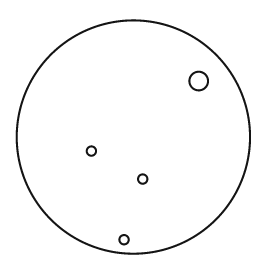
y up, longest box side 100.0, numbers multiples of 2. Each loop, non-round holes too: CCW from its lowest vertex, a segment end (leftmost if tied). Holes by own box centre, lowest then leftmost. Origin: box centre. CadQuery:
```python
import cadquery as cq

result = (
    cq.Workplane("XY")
    .moveTo(0.0, 0.0)
    .circle(50.0)
    .moveTo(-4.0, -44.0)
    .circle(2.0)
    .moveTo(4.0, -18.0)
    .circle(2.0)
    .moveTo(-18.0, -6.0)
    .circle(2.0)
    .moveTo(28.0, 24.0)
    .circle(4.0)
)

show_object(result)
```